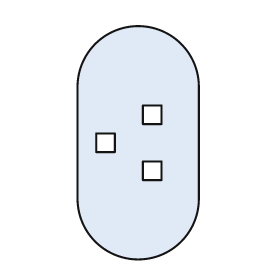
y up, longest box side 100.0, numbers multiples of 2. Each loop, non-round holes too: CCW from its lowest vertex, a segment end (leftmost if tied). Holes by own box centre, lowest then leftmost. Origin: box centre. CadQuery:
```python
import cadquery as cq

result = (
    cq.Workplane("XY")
    .moveTo(-26.0, -24.0)
    .threePointArc((0.0, -50.0), (26.0, -24.0))
    .lineTo(26.0, 24.0)
    .threePointArc((0.0, 50.0), (-26.0, 24.0))
    .close()
    .moveTo(2.0, -16.0)
    .lineTo(10.0, -16.0)
    .lineTo(10.0, -8.0)
    .lineTo(2.0, -8.0)
    .close()
    .moveTo(-18.0, -4.0)
    .lineTo(-10.0, -4.0)
    .lineTo(-10.0, 4.0)
    .lineTo(-18.0, 4.0)
    .close()
    .moveTo(2.0, 8.0)
    .lineTo(10.0, 8.0)
    .lineTo(10.0, 16.0)
    .lineTo(2.0, 16.0)
    .close()
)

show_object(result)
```